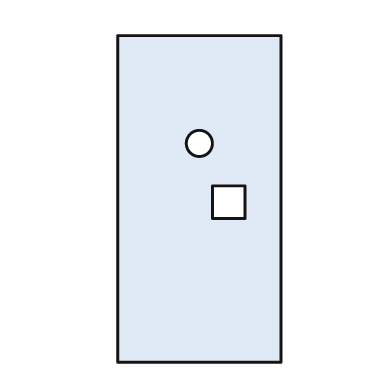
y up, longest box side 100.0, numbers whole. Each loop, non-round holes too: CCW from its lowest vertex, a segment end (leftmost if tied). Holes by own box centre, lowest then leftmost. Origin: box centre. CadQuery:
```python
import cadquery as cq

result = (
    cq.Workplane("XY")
    .moveTo(-25.0, -50.0)
    .lineTo(25.0, -50.0)
    .lineTo(25.0, 50.0)
    .lineTo(-25.0, 50.0)
    .close()
    .moveTo(4.0, -6.0)
    .lineTo(14.0, -6.0)
    .lineTo(14.0, 4.0)
    .lineTo(4.0, 4.0)
    .close()
    .moveTo(0.0, 17.0)
    .circle(4.0)
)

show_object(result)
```